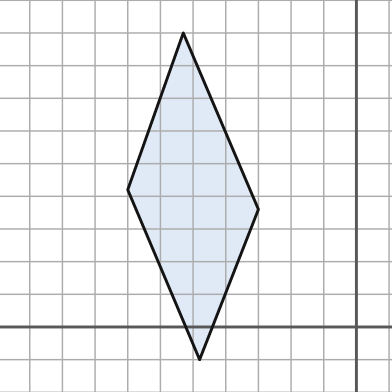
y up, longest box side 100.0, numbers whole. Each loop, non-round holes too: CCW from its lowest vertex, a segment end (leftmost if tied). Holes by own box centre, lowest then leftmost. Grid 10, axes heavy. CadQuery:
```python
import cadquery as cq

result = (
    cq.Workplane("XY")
    .moveTo(-48.0, -10.0)
    .lineTo(-30.0, 36.0)
    .lineTo(-53.0, 90.0)
    .lineTo(-70.0, 42.0)
    .close()
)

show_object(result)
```